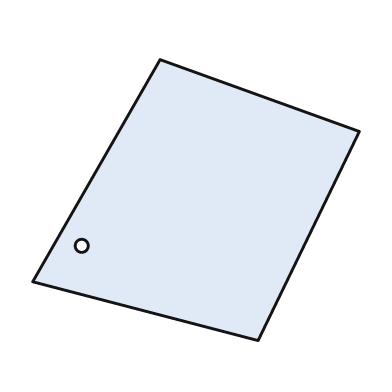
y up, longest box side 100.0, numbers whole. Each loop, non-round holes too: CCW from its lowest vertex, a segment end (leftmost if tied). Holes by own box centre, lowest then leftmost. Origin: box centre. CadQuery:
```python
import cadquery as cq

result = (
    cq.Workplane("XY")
    .moveTo(19.0, -43.0)
    .lineTo(50.0, 21.0)
    .lineTo(-11.0, 43.0)
    .lineTo(-50.0, -25.0)
    .close()
    .moveTo(-35.0, -14.0)
    .circle(2.0)
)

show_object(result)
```